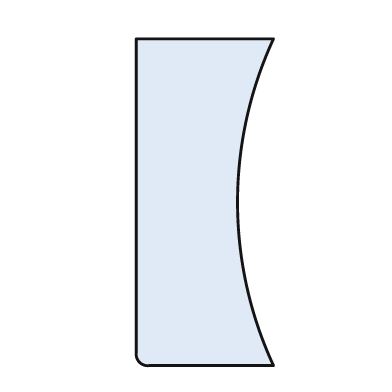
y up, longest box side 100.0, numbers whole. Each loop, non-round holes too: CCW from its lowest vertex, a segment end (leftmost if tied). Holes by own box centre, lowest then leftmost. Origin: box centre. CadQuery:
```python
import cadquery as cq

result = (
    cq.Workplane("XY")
    .moveTo(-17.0, -50.0)
    .lineTo(21.0, -50.0)
    .threePointArc((10.0, 0.0), (21.0, 50.0))
    .lineTo(-21.0, 50.0)
    .lineTo(-21.0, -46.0)
    .threePointArc((-20.0, -49.0), (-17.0, -50.0))
    .close()
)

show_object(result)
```